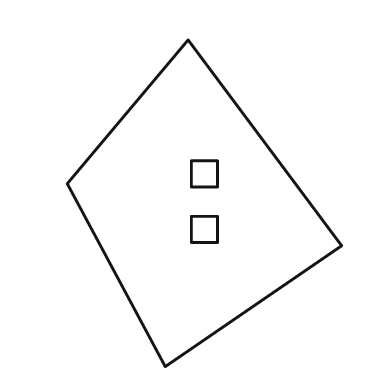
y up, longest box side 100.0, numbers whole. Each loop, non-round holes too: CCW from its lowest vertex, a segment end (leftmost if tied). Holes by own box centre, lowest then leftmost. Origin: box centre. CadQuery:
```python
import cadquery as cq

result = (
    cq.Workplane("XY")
    .moveTo(-12.0, -50.0)
    .lineTo(42.0, -13.0)
    .lineTo(-5.0, 50.0)
    .lineTo(-42.0, 6.0)
    .close()
    .moveTo(-4.0, -12.0)
    .lineTo(4.0, -12.0)
    .lineTo(4.0, -4.0)
    .lineTo(-4.0, -4.0)
    .close()
    .moveTo(-4.0, 5.0)
    .lineTo(4.0, 5.0)
    .lineTo(4.0, 13.0)
    .lineTo(-4.0, 13.0)
    .close()
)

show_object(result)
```